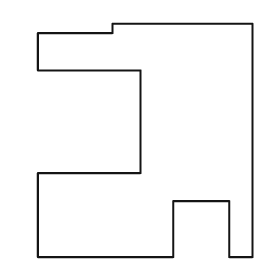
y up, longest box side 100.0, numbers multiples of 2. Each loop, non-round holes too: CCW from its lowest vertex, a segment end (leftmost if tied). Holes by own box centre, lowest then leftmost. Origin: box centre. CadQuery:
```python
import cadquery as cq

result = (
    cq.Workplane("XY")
    .moveTo(-46.0, -50.0)
    .lineTo(12.0, -50.0)
    .lineTo(12.0, -26.0)
    .lineTo(36.0, -26.0)
    .lineTo(36.0, -50.0)
    .lineTo(46.0, -50.0)
    .lineTo(46.0, 50.0)
    .lineTo(-14.0, 50.0)
    .lineTo(-14.0, 46.0)
    .lineTo(-46.0, 46.0)
    .lineTo(-46.0, 30.0)
    .lineTo(-2.0, 30.0)
    .lineTo(-2.0, -14.0)
    .lineTo(-46.0, -14.0)
    .close()
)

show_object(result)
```